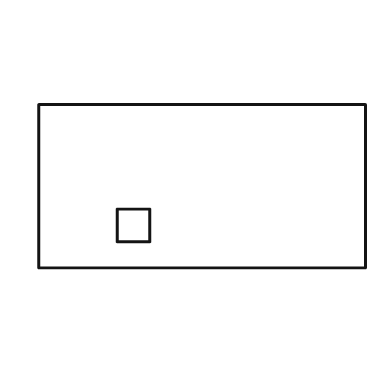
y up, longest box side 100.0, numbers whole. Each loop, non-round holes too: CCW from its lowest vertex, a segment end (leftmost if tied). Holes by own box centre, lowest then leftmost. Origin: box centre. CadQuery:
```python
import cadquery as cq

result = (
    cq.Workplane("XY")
    .moveTo(-50.0, -25.0)
    .lineTo(50.0, -25.0)
    .lineTo(50.0, 25.0)
    .lineTo(-50.0, 25.0)
    .close()
    .moveTo(-26.0, -17.0)
    .lineTo(-16.0, -17.0)
    .lineTo(-16.0, -7.0)
    .lineTo(-26.0, -7.0)
    .close()
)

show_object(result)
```